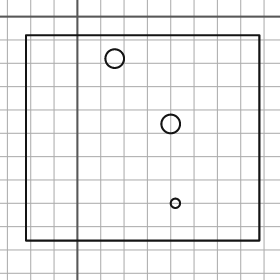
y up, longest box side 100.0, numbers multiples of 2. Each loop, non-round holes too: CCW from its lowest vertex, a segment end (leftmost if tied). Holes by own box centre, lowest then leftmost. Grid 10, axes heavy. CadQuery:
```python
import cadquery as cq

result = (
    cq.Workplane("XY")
    .moveTo(-22.0, -96.0)
    .lineTo(78.0, -96.0)
    .lineTo(78.0, -8.0)
    .lineTo(-22.0, -8.0)
    .close()
    .moveTo(42.0, -80.0)
    .circle(2.0)
    .moveTo(40.0, -46.0)
    .circle(4.0)
    .moveTo(16.0, -18.0)
    .circle(4.0)
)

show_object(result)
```